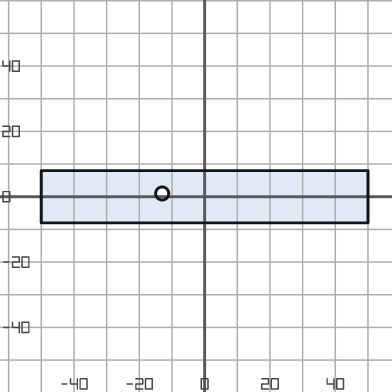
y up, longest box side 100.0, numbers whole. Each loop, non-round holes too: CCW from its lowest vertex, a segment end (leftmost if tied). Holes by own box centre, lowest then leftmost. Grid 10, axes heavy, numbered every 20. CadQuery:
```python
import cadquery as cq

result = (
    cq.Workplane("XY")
    .moveTo(-50.0, -8.0)
    .lineTo(50.0, -8.0)
    .lineTo(50.0, 8.0)
    .lineTo(-50.0, 8.0)
    .close()
    .moveTo(-13.0, 1.0)
    .circle(2.0)
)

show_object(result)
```